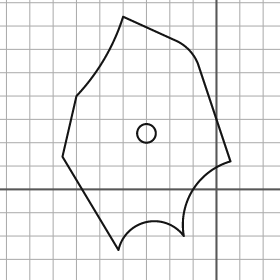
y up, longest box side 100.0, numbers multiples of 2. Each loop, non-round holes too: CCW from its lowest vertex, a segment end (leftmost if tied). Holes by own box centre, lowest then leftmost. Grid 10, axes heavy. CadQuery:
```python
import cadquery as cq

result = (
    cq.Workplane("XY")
    .moveTo(-42.0, -26.0)
    .threePointArc((-30.0, -14.0), (-14.0, -20.0))
    .threePointArc((-10.0, 0.0), (6.0, 12.0))
    .lineTo(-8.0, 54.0)
    .threePointArc((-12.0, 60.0), (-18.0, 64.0))
    .lineTo(-40.0, 74.0)
    .threePointArc((-48.0, 56.0), (-60.0, 40.0))
    .lineTo(-66.0, 14.0)
    .close()
    .moveTo(-30.0, 24.0)
    .circle(4.0)
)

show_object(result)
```